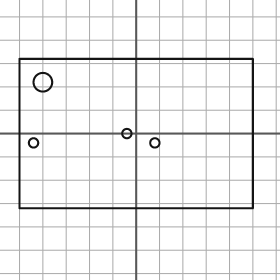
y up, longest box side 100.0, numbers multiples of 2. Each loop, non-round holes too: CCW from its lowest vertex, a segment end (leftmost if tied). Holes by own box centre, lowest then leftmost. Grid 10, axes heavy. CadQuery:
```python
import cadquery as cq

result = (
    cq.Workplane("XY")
    .moveTo(-50.0, -32.0)
    .lineTo(50.0, -32.0)
    .lineTo(50.0, 32.0)
    .lineTo(-50.0, 32.0)
    .close()
    .moveTo(-44.0, -4.0)
    .circle(2.0)
    .moveTo(8.0, -4.0)
    .circle(2.0)
    .moveTo(-4.0, 0.0)
    .circle(2.0)
    .moveTo(-40.0, 22.0)
    .circle(4.0)
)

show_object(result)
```